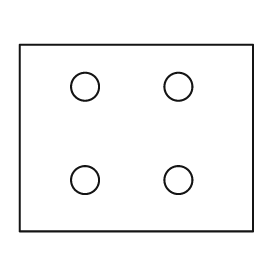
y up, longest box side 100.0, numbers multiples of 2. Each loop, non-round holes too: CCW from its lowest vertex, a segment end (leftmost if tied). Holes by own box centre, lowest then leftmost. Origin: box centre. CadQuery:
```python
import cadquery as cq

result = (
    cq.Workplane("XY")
    .moveTo(-50.0, -40.0)
    .lineTo(50.0, -40.0)
    .lineTo(50.0, 40.0)
    .lineTo(-50.0, 40.0)
    .close()
    .moveTo(-22.0, -18.0)
    .circle(6.0)
    .moveTo(18.0, -18.0)
    .circle(6.0)
    .moveTo(-22.0, 22.0)
    .circle(6.0)
    .moveTo(18.0, 22.0)
    .circle(6.0)
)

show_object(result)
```